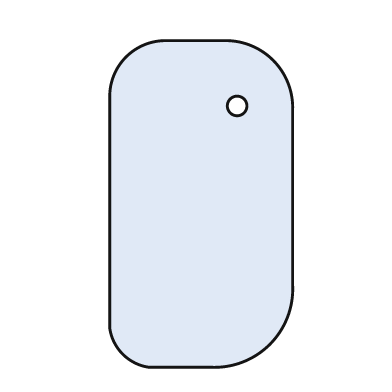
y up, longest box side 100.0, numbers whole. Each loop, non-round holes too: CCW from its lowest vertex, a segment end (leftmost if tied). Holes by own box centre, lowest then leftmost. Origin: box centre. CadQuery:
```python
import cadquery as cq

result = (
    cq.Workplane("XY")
    .moveTo(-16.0, -50.0)
    .lineTo(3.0, -50.0)
    .threePointArc((21.0, -43.0), (28.0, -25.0))
    .lineTo(28.0, 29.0)
    .threePointArc((22.0, 44.0), (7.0, 50.0))
    .lineTo(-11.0, 50.0)
    .threePointArc((-23.0, 45.0), (-28.0, 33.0))
    .lineTo(-28.0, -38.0)
    .threePointArc((-24.0, -46.0), (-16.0, -50.0))
    .close()
    .moveTo(11.0, 30.0)
    .circle(3.0)
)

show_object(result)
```